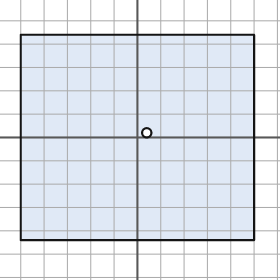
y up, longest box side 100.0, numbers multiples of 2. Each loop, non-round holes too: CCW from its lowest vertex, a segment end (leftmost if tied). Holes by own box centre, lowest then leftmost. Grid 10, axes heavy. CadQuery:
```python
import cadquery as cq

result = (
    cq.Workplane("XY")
    .moveTo(-50.0, -44.0)
    .lineTo(50.0, -44.0)
    .lineTo(50.0, 44.0)
    .lineTo(-50.0, 44.0)
    .close()
    .moveTo(4.0, 2.0)
    .circle(2.0)
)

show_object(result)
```